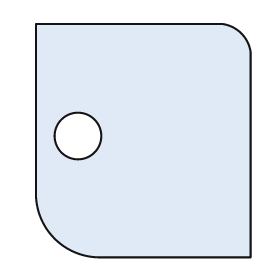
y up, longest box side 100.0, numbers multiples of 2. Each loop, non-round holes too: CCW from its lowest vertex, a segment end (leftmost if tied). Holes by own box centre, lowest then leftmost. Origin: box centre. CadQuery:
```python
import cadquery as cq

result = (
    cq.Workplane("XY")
    .moveTo(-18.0, -50.0)
    .lineTo(46.0, -50.0)
    .lineTo(46.0, 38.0)
    .threePointArc((42.0, 46.0), (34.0, 50.0))
    .lineTo(-46.0, 50.0)
    .lineTo(-46.0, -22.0)
    .threePointArc((-38.0, -42.0), (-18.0, -50.0))
    .close()
    .moveTo(-28.0, 2.0)
    .circle(10.0)
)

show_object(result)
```